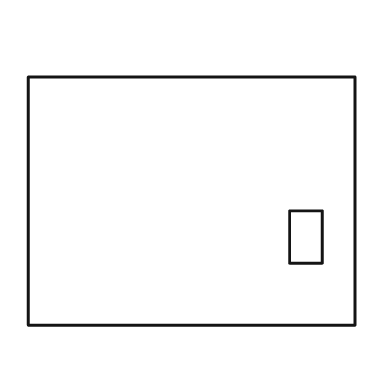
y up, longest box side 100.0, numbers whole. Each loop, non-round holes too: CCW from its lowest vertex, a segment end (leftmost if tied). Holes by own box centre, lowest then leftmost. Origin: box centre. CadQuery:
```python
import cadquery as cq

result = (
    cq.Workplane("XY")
    .moveTo(-50.0, -38.0)
    .lineTo(50.0, -38.0)
    .lineTo(50.0, 38.0)
    .lineTo(-50.0, 38.0)
    .close()
    .moveTo(30.0, -19.0)
    .lineTo(40.0, -19.0)
    .lineTo(40.0, -3.0)
    .lineTo(30.0, -3.0)
    .close()
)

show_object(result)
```